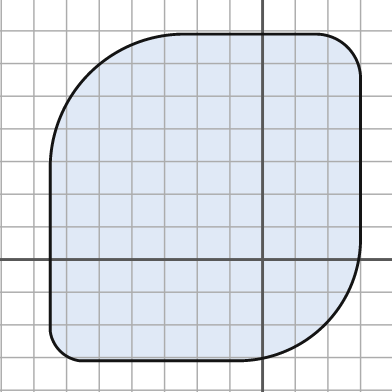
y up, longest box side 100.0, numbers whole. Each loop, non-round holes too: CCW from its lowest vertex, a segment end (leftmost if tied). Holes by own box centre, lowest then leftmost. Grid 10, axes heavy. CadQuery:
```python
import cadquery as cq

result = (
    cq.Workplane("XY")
    .moveTo(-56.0, -31.0)
    .lineTo(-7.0, -31.0)
    .threePointArc((19.0, -20.0), (30.0, 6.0))
    .lineTo(30.0, 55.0)
    .threePointArc((26.0, 65.0), (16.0, 69.0))
    .lineTo(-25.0, 69.0)
    .threePointArc((-53.0, 57.0), (-65.0, 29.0))
    .lineTo(-65.0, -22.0)
    .threePointArc((-62.0, -28.0), (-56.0, -31.0))
    .close()
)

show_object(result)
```